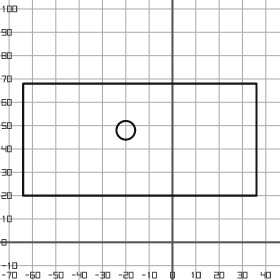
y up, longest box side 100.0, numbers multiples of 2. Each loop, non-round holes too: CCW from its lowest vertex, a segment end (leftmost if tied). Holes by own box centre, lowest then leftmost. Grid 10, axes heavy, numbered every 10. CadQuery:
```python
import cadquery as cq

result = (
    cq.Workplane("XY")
    .moveTo(-64.0, 20.0)
    .lineTo(36.0, 20.0)
    .lineTo(36.0, 68.0)
    .lineTo(-64.0, 68.0)
    .close()
    .moveTo(-20.0, 48.0)
    .circle(4.0)
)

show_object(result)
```